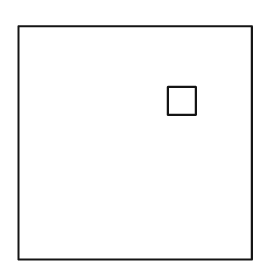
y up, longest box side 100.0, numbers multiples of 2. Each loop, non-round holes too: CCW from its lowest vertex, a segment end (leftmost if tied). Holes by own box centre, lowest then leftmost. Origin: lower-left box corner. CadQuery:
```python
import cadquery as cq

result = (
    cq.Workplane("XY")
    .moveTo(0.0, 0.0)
    .lineTo(100.0, 0.0)
    .lineTo(100.0, 100.0)
    .lineTo(0.0, 100.0)
    .close()
    .moveTo(64.0, 62.0)
    .lineTo(76.0, 62.0)
    .lineTo(76.0, 74.0)
    .lineTo(64.0, 74.0)
    .close()
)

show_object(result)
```